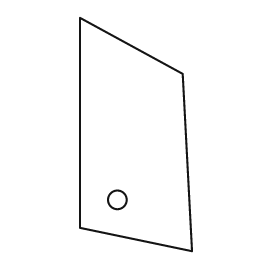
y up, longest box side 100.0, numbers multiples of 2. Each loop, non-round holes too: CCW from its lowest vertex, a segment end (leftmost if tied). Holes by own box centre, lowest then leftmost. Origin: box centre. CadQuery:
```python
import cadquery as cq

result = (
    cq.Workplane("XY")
    .moveTo(24.0, -50.0)
    .lineTo(20.0, 26.0)
    .lineTo(-24.0, 50.0)
    .lineTo(-24.0, -40.0)
    .close()
    .moveTo(-8.0, -28.0)
    .circle(4.0)
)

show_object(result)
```